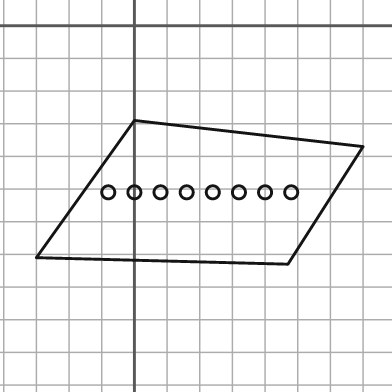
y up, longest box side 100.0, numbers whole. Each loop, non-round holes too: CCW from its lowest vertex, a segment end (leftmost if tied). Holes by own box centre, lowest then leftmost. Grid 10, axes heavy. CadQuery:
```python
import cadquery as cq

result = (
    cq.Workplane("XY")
    .moveTo(47.0, -73.0)
    .lineTo(70.0, -37.0)
    .lineTo(0.0, -29.0)
    .lineTo(-30.0, -71.0)
    .close()
    .moveTo(-8.0, -51.0)
    .circle(2.0)
    .moveTo(0.0, -51.0)
    .circle(2.0)
    .moveTo(8.0, -51.0)
    .circle(2.0)
    .moveTo(16.0, -51.0)
    .circle(2.0)
    .moveTo(24.0, -51.0)
    .circle(2.0)
    .moveTo(32.0, -51.0)
    .circle(2.0)
    .moveTo(40.0, -51.0)
    .circle(2.0)
    .moveTo(48.0, -51.0)
    .circle(2.0)
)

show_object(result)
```